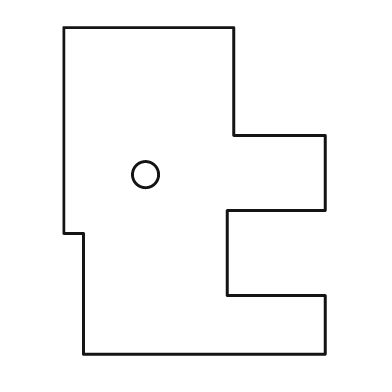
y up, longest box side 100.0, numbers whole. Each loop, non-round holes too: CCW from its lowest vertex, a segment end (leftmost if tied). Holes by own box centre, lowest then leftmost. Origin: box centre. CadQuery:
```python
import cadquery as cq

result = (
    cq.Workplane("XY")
    .moveTo(-34.0, -50.0)
    .lineTo(40.0, -50.0)
    .lineTo(40.0, -32.0)
    .lineTo(10.0, -32.0)
    .lineTo(10.0, -6.0)
    .lineTo(40.0, -6.0)
    .lineTo(40.0, 17.0)
    .lineTo(12.0, 17.0)
    .lineTo(12.0, 50.0)
    .lineTo(-40.0, 50.0)
    .lineTo(-40.0, -13.0)
    .lineTo(-34.0, -13.0)
    .close()
    .moveTo(-15.0, 5.0)
    .circle(4.0)
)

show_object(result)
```